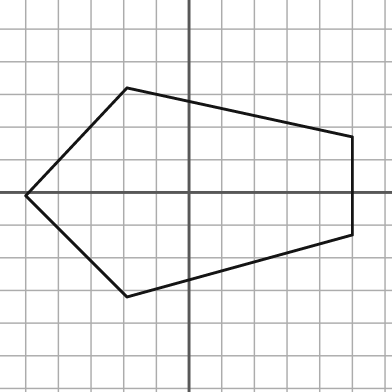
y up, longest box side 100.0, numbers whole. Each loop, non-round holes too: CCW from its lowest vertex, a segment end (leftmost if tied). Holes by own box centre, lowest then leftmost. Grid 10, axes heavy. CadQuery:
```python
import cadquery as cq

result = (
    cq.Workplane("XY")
    .moveTo(-19.0, -32.0)
    .lineTo(50.0, -13.0)
    .lineTo(50.0, 17.0)
    .lineTo(-19.0, 32.0)
    .lineTo(-50.0, -1.0)
    .close()
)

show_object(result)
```